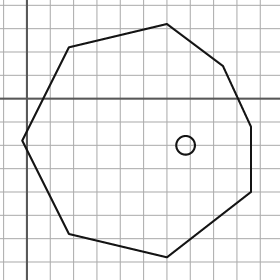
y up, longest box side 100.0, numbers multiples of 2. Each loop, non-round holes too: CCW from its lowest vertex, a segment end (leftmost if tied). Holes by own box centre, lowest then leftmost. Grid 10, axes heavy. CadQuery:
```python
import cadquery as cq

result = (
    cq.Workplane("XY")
    .moveTo(60.0, -68.0)
    .lineTo(96.0, -40.0)
    .lineTo(96.0, -12.0)
    .lineTo(84.0, 14.0)
    .lineTo(60.0, 32.0)
    .lineTo(18.0, 22.0)
    .lineTo(-2.0, -18.0)
    .lineTo(18.0, -58.0)
    .close()
    .moveTo(68.0, -20.0)
    .circle(4.0)
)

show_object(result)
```